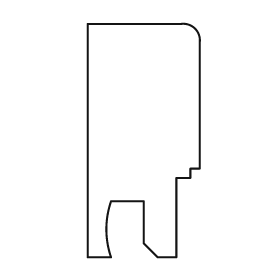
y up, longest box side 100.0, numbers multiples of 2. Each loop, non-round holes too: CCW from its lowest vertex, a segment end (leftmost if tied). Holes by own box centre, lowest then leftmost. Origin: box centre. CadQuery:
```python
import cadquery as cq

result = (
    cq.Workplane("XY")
    .moveTo(-24.0, -50.0)
    .lineTo(-14.0, -50.0)
    .threePointArc((-16.0, -38.0), (-14.0, -26.0))
    .lineTo(0.0, -26.0)
    .lineTo(0.0, -44.0)
    .lineTo(6.0, -50.0)
    .lineTo(14.0, -50.0)
    .lineTo(14.0, -16.0)
    .lineTo(20.0, -16.0)
    .lineTo(20.0, -12.0)
    .lineTo(24.0, -12.0)
    .lineTo(24.0, 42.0)
    .threePointArc((22.0, 48.0), (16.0, 50.0))
    .lineTo(-24.0, 50.0)
    .close()
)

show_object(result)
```